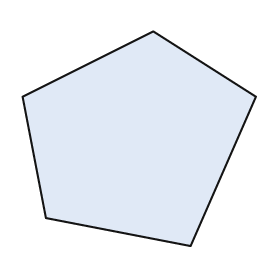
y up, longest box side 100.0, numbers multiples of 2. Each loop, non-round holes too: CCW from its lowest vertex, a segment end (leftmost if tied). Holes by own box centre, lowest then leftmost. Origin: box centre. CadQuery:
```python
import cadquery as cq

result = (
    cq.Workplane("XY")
    .moveTo(22.0, -46.0)
    .lineTo(50.0, 18.0)
    .lineTo(6.0, 46.0)
    .lineTo(-50.0, 18.0)
    .lineTo(-40.0, -34.0)
    .close()
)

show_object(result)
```